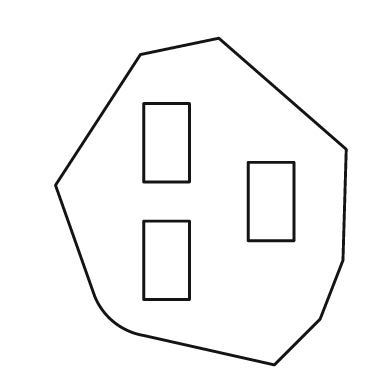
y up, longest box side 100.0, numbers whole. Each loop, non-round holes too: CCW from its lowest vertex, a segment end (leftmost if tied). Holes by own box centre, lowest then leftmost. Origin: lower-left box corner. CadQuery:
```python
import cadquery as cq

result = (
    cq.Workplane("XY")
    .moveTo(67.0, 0.0)
    .lineTo(81.0, 14.0)
    .lineTo(88.0, 32.0)
    .lineTo(89.0, 66.0)
    .lineTo(50.0, 100.0)
    .lineTo(26.0, 95.0)
    .lineTo(0.0, 55.0)
    .lineTo(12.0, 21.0)
    .threePointArc((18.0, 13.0), (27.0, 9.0))
    .close()
    .moveTo(27.0, 20.0)
    .lineTo(41.0, 20.0)
    .lineTo(41.0, 44.0)
    .lineTo(27.0, 44.0)
    .close()
    .moveTo(59.0, 38.0)
    .lineTo(73.0, 38.0)
    .lineTo(73.0, 62.0)
    .lineTo(59.0, 62.0)
    .close()
    .moveTo(27.0, 56.0)
    .lineTo(41.0, 56.0)
    .lineTo(41.0, 80.0)
    .lineTo(27.0, 80.0)
    .close()
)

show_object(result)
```